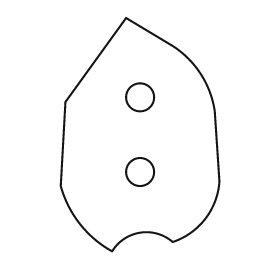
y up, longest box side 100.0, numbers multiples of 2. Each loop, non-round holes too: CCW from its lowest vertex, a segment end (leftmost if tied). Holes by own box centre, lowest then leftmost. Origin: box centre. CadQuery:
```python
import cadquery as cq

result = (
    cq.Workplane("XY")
    .moveTo(-12.0, -50.0)
    .threePointArc((0.0, -42.0), (14.0, -46.0))
    .threePointArc((28.0, -36.0), (34.0, -20.0))
    .lineTo(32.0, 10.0)
    .threePointArc((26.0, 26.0), (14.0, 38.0))
    .lineTo(-6.0, 50.0)
    .lineTo(-32.0, 14.0)
    .lineTo(-34.0, -22.0)
    .threePointArc((-26.0, -38.0), (-12.0, -50.0))
    .close()
    .moveTo(0.0, -16.0)
    .circle(6.0)
    .moveTo(0.0, 16.0)
    .circle(6.0)
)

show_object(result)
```